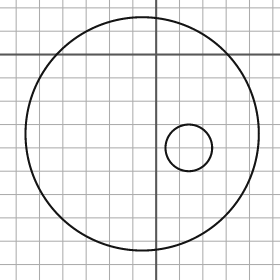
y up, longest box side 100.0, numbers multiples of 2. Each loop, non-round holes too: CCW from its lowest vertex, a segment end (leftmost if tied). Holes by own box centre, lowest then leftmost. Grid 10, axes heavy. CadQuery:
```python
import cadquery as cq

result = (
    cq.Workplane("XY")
    .moveTo(-6.0, -34.0)
    .circle(50.0)
    .moveTo(14.0, -40.0)
    .circle(10.0)
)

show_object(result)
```